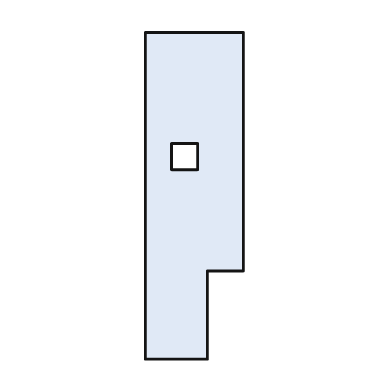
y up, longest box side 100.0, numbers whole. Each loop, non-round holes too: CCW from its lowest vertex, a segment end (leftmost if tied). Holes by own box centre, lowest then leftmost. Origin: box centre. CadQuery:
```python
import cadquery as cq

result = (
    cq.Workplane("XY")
    .moveTo(-15.0, -50.0)
    .lineTo(4.0, -50.0)
    .lineTo(4.0, -23.0)
    .lineTo(15.0, -23.0)
    .lineTo(15.0, 50.0)
    .lineTo(-15.0, 50.0)
    .close()
    .moveTo(-7.0, 8.0)
    .lineTo(1.0, 8.0)
    .lineTo(1.0, 16.0)
    .lineTo(-7.0, 16.0)
    .close()
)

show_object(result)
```